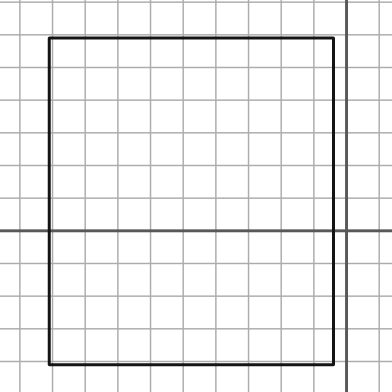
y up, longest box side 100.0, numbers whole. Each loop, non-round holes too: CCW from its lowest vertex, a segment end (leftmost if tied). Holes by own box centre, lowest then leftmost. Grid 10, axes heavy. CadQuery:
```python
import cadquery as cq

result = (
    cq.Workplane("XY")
    .moveTo(-91.0, -41.0)
    .lineTo(-4.0, -41.0)
    .lineTo(-4.0, 59.0)
    .lineTo(-91.0, 59.0)
    .close()
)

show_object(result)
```